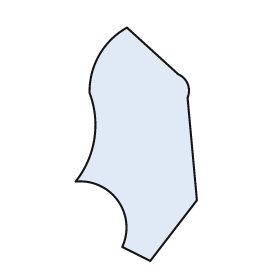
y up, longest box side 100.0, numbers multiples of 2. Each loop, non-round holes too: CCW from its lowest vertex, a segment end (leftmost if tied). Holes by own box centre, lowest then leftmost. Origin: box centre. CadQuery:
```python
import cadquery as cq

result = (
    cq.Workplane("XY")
    .moveTo(6.0, -50.0)
    .lineTo(26.0, -24.0)
    .lineTo(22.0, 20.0)
    .threePointArc((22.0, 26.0), (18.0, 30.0))
    .lineTo(-4.0, 50.0)
    .threePointArc((-16.0, 38.0), (-20.0, 22.0))
    .threePointArc((-18.0, 2.0), (-26.0, -16.0))
    .threePointArc((-8.0, -24.0), (-6.0, -44.0))
    .close()
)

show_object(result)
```